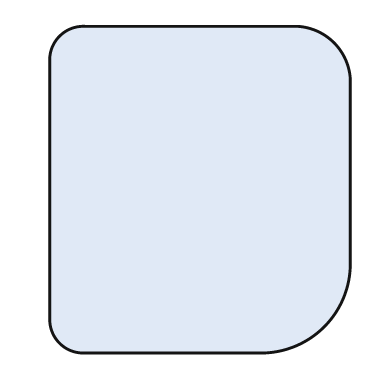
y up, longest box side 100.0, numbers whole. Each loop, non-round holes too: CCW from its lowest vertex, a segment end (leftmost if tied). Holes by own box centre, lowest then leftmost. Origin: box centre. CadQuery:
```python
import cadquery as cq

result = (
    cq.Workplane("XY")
    .moveTo(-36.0, -50.0)
    .lineTo(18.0, -50.0)
    .threePointArc((38.0, -42.0), (46.0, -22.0))
    .lineTo(46.0, 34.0)
    .threePointArc((41.0, 45.0), (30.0, 50.0))
    .lineTo(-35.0, 50.0)
    .threePointArc((-43.0, 47.0), (-46.0, 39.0))
    .lineTo(-46.0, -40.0)
    .threePointArc((-43.0, -47.0), (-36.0, -50.0))
    .close()
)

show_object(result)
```